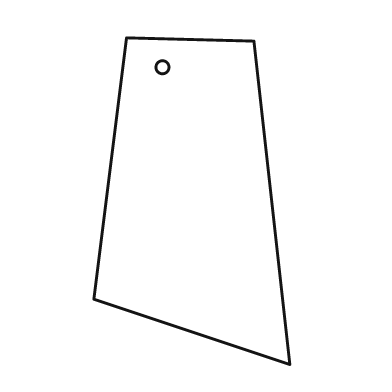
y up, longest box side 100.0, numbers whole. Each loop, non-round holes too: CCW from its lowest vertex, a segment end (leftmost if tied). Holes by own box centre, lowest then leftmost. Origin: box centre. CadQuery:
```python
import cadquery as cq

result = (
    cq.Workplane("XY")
    .moveTo(30.0, -50.0)
    .lineTo(19.0, 49.0)
    .lineTo(-20.0, 50.0)
    .lineTo(-30.0, -30.0)
    .close()
    .moveTo(-9.0, 41.0)
    .circle(2.0)
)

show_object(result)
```